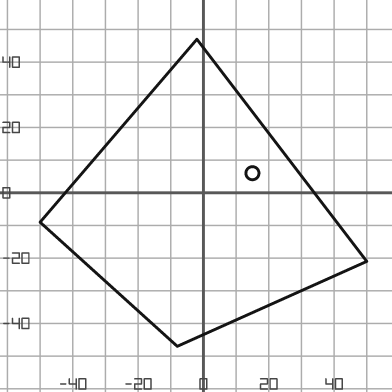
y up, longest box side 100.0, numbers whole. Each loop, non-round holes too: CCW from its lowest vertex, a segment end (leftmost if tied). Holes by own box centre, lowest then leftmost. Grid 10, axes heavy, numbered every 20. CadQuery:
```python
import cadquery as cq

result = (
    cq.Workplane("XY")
    .moveTo(-8.0, -47.0)
    .lineTo(50.0, -21.0)
    .lineTo(-2.0, 47.0)
    .lineTo(-50.0, -9.0)
    .close()
    .moveTo(15.0, 6.0)
    .circle(2.0)
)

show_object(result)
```